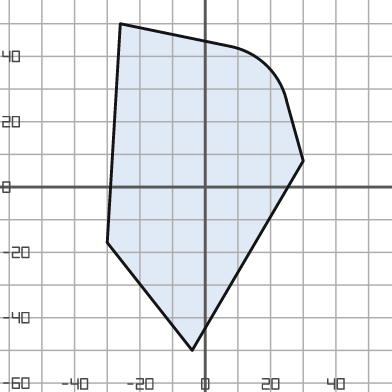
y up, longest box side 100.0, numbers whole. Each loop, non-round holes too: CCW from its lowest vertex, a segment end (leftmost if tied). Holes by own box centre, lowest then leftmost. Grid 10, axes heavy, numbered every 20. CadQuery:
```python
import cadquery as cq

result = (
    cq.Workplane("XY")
    .moveTo(-4.0, -50.0)
    .lineTo(30.0, 8.0)
    .lineTo(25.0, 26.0)
    .threePointArc((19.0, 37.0), (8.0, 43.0))
    .lineTo(-26.0, 50.0)
    .lineTo(-30.0, -17.0)
    .close()
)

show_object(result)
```